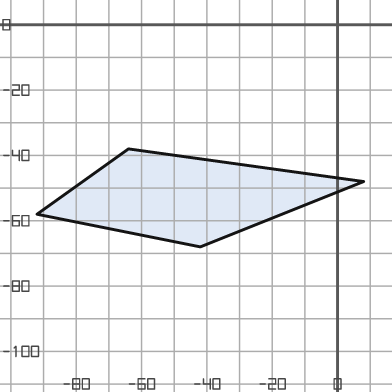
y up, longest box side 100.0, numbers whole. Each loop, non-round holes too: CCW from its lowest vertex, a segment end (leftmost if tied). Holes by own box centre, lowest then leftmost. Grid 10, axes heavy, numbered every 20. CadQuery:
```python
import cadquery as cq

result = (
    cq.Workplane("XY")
    .moveTo(-42.0, -68.0)
    .lineTo(8.0, -48.0)
    .lineTo(-64.0, -38.0)
    .lineTo(-92.0, -58.0)
    .close()
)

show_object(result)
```